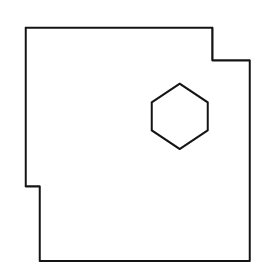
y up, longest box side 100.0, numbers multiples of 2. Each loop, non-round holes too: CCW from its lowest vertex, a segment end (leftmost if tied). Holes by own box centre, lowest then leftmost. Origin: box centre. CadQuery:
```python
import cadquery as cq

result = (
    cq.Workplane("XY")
    .moveTo(-42.0, -50.0)
    .lineTo(48.0, -50.0)
    .lineTo(48.0, 36.0)
    .lineTo(32.0, 36.0)
    .lineTo(32.0, 50.0)
    .lineTo(-48.0, 50.0)
    .lineTo(-48.0, -18.0)
    .lineTo(-42.0, -18.0)
    .close()
    .moveTo(18.0, -2.0)
    .lineTo(30.0, 6.0)
    .lineTo(30.0, 18.0)
    .lineTo(18.0, 26.0)
    .lineTo(6.0, 18.0)
    .lineTo(6.0, 6.0)
    .close()
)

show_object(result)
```